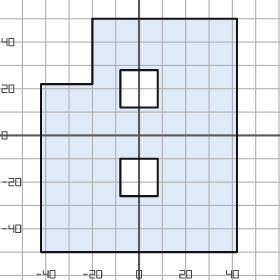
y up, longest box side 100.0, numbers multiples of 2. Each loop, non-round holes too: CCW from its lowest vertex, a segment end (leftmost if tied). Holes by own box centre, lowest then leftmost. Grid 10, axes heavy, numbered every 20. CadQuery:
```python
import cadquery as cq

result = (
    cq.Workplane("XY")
    .moveTo(-42.0, -50.0)
    .lineTo(42.0, -50.0)
    .lineTo(42.0, 50.0)
    .lineTo(-20.0, 50.0)
    .lineTo(-20.0, 22.0)
    .lineTo(-42.0, 22.0)
    .close()
    .moveTo(-8.0, -26.0)
    .lineTo(8.0, -26.0)
    .lineTo(8.0, -10.0)
    .lineTo(-8.0, -10.0)
    .close()
    .moveTo(-8.0, 12.0)
    .lineTo(8.0, 12.0)
    .lineTo(8.0, 28.0)
    .lineTo(-8.0, 28.0)
    .close()
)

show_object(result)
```